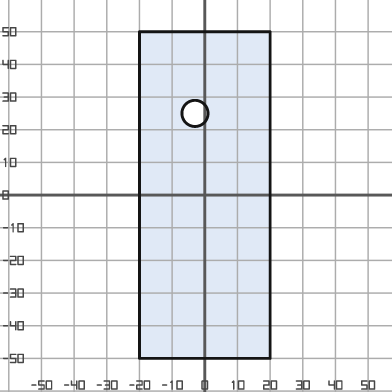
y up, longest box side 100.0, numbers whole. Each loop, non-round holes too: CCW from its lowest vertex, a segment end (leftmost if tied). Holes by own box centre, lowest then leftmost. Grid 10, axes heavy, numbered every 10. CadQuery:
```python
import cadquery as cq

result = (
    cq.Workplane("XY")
    .moveTo(-20.0, -50.0)
    .lineTo(20.0, -50.0)
    .lineTo(20.0, 50.0)
    .lineTo(-20.0, 50.0)
    .close()
    .moveTo(-3.0, 25.0)
    .circle(4.0)
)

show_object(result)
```